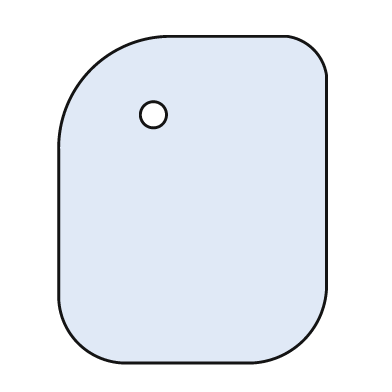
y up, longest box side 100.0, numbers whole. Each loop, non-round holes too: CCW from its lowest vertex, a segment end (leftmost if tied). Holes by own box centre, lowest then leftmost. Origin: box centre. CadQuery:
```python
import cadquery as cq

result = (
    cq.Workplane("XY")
    .moveTo(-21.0, -50.0)
    .lineTo(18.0, -50.0)
    .threePointArc((34.0, -43.0), (41.0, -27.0))
    .lineTo(41.0, 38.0)
    .threePointArc((37.0, 46.0), (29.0, 50.0))
    .lineTo(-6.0, 50.0)
    .threePointArc((-31.0, 40.0), (-41.0, 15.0))
    .lineTo(-41.0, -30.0)
    .threePointArc((-35.0, -44.0), (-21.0, -50.0))
    .close()
    .moveTo(-12.0, 26.0)
    .circle(4.0)
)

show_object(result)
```